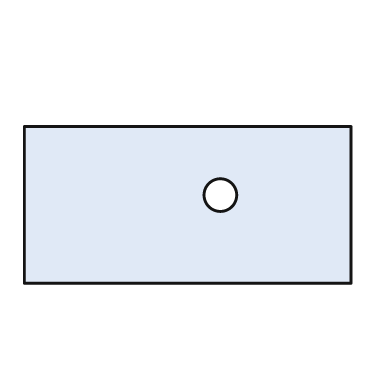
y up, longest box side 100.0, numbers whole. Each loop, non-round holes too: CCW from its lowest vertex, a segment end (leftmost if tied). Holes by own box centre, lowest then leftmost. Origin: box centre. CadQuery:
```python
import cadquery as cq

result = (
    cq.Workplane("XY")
    .moveTo(-50.0, -24.0)
    .lineTo(50.0, -24.0)
    .lineTo(50.0, 24.0)
    .lineTo(-50.0, 24.0)
    .close()
    .moveTo(10.0, 3.0)
    .circle(5.0)
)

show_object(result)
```